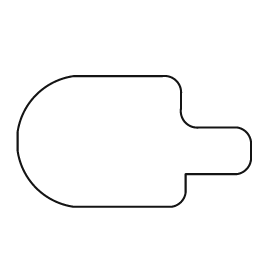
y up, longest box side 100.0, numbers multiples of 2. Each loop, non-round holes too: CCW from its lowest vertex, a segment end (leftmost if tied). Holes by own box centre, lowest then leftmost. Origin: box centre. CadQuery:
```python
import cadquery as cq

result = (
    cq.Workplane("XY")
    .moveTo(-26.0, -28.0)
    .lineTo(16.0, -28.0)
    .threePointArc((20.0, -26.0), (22.0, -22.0))
    .lineTo(22.0, -14.0)
    .lineTo(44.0, -14.0)
    .threePointArc((48.0, -12.0), (50.0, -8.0))
    .lineTo(50.0, 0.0)
    .threePointArc((48.0, 4.0), (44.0, 6.0))
    .lineTo(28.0, 6.0)
    .threePointArc((22.0, 8.0), (20.0, 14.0))
    .lineTo(20.0, 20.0)
    .threePointArc((18.0, 26.0), (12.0, 28.0))
    .lineTo(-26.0, 28.0)
    .threePointArc((-42.0, 20.0), (-50.0, 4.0))
    .lineTo(-50.0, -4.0)
    .threePointArc((-42.0, -20.0), (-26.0, -28.0))
    .close()
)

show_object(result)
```